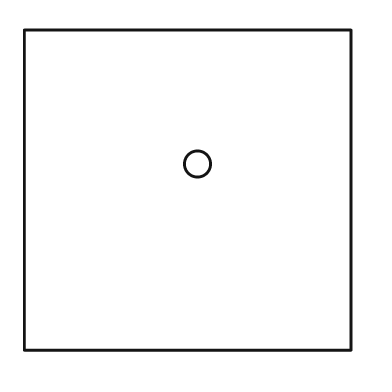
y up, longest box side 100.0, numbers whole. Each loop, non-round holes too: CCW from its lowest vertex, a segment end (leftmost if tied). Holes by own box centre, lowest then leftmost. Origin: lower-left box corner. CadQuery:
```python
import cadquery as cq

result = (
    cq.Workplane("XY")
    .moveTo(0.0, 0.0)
    .lineTo(100.0, 0.0)
    .lineTo(100.0, 98.0)
    .lineTo(0.0, 98.0)
    .close()
    .moveTo(53.0, 57.0)
    .circle(4.0)
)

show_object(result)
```